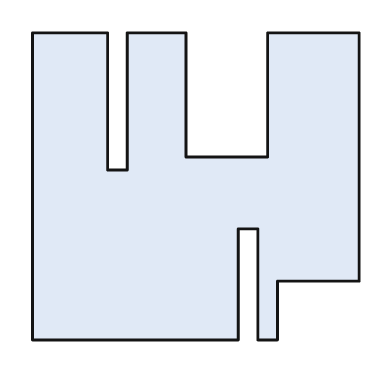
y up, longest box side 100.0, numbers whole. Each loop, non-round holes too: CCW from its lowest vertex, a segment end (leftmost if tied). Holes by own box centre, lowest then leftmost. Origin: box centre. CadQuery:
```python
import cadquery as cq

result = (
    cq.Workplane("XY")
    .moveTo(-50.0, -47.0)
    .lineTo(13.0, -47.0)
    .lineTo(13.0, -13.0)
    .lineTo(19.0, -13.0)
    .lineTo(19.0, -47.0)
    .lineTo(25.0, -47.0)
    .lineTo(25.0, -29.0)
    .lineTo(50.0, -29.0)
    .lineTo(50.0, 47.0)
    .lineTo(22.0, 47.0)
    .lineTo(22.0, 9.0)
    .lineTo(-3.0, 9.0)
    .lineTo(-3.0, 47.0)
    .lineTo(-21.0, 47.0)
    .lineTo(-21.0, 5.0)
    .lineTo(-27.0, 5.0)
    .lineTo(-27.0, 47.0)
    .lineTo(-50.0, 47.0)
    .close()
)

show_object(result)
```